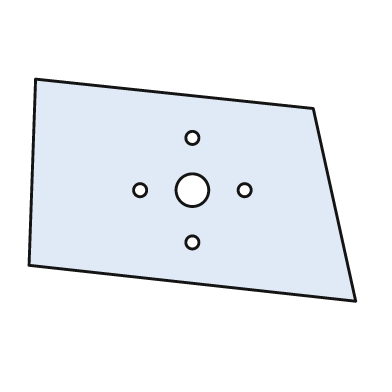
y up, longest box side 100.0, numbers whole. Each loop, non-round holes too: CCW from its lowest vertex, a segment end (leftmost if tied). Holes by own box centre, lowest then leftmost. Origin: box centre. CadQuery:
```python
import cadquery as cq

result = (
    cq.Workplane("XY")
    .moveTo(50.0, -34.0)
    .lineTo(37.0, 25.0)
    .lineTo(-48.0, 34.0)
    .lineTo(-50.0, -23.0)
    .close()
    .moveTo(0.0, -16.0)
    .circle(2.0)
    .moveTo(-16.0, 0.0)
    .circle(2.0)
    .moveTo(0.0, 0.0)
    .circle(5.0)
    .moveTo(16.0, 0.0)
    .circle(2.0)
    .moveTo(0.0, 16.0)
    .circle(2.0)
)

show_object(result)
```